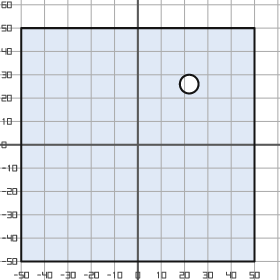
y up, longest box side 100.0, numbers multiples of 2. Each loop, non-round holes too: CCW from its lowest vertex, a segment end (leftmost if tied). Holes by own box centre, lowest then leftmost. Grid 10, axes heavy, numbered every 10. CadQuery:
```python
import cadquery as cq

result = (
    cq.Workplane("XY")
    .moveTo(-50.0, -50.0)
    .lineTo(50.0, -50.0)
    .lineTo(50.0, 50.0)
    .lineTo(-50.0, 50.0)
    .close()
    .moveTo(22.0, 26.0)
    .circle(4.0)
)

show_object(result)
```